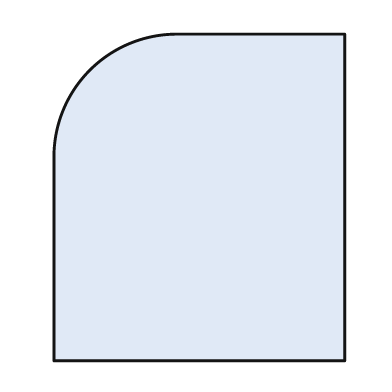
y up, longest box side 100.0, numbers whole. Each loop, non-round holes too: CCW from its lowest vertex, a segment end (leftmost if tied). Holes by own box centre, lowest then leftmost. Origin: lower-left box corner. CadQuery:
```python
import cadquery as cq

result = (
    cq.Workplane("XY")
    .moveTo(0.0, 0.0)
    .lineTo(89.0, 0.0)
    .lineTo(89.0, 100.0)
    .lineTo(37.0, 100.0)
    .threePointArc((11.0, 89.0), (0.0, 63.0))
    .close()
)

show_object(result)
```